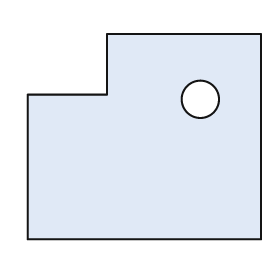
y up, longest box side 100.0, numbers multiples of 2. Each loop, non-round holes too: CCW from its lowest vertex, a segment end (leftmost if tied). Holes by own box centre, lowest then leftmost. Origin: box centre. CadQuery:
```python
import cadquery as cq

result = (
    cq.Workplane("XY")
    .moveTo(-50.0, -44.0)
    .lineTo(50.0, -44.0)
    .lineTo(50.0, 44.0)
    .lineTo(-16.0, 44.0)
    .lineTo(-16.0, 18.0)
    .lineTo(-50.0, 18.0)
    .close()
    .moveTo(24.0, 16.0)
    .circle(8.0)
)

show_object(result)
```